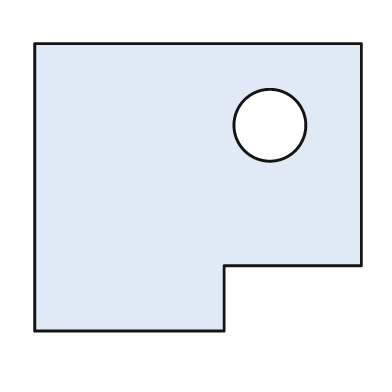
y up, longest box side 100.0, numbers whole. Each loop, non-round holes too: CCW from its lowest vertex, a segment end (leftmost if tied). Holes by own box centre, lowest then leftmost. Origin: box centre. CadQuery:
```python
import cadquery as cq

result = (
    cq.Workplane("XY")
    .moveTo(-50.0, -44.0)
    .lineTo(8.0, -44.0)
    .lineTo(8.0, -24.0)
    .lineTo(50.0, -24.0)
    .lineTo(50.0, 44.0)
    .lineTo(-50.0, 44.0)
    .close()
    .moveTo(22.0, 19.0)
    .circle(11.0)
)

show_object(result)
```